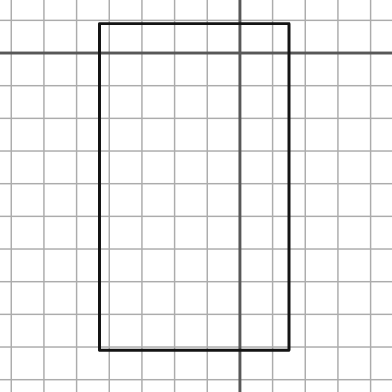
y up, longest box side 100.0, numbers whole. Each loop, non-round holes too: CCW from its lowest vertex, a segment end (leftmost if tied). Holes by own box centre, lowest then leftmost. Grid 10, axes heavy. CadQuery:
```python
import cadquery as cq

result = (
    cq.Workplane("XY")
    .moveTo(-43.0, -91.0)
    .lineTo(15.0, -91.0)
    .lineTo(15.0, 9.0)
    .lineTo(-43.0, 9.0)
    .close()
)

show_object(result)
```